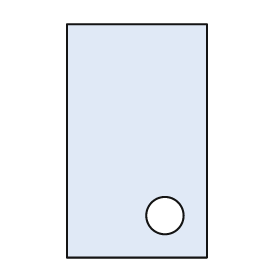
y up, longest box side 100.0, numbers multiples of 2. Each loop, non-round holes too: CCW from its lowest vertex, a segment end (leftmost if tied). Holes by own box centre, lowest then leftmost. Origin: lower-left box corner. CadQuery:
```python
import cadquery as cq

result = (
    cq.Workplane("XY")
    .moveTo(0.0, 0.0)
    .lineTo(60.0, 0.0)
    .lineTo(60.0, 100.0)
    .lineTo(0.0, 100.0)
    .close()
    .moveTo(42.0, 18.0)
    .circle(8.0)
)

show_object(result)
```